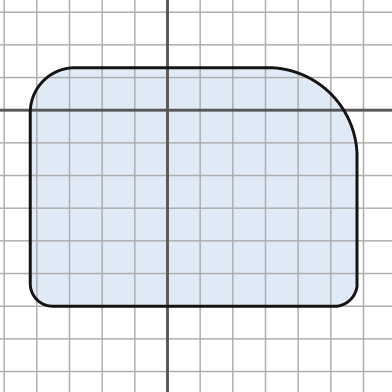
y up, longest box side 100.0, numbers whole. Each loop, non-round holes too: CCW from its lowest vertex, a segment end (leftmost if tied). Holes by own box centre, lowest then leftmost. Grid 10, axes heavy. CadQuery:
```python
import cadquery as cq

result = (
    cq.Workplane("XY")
    .moveTo(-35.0, -60.0)
    .lineTo(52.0, -60.0)
    .threePointArc((56.0, -58.0), (58.0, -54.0))
    .lineTo(58.0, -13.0)
    .threePointArc((50.0, 5.0), (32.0, 13.0))
    .lineTo(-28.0, 13.0)
    .threePointArc((-38.0, 9.0), (-42.0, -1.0))
    .lineTo(-42.0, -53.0)
    .threePointArc((-40.0, -58.0), (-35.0, -60.0))
    .close()
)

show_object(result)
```